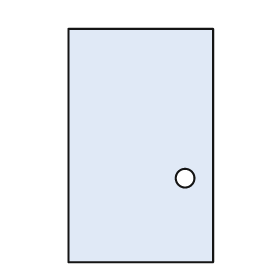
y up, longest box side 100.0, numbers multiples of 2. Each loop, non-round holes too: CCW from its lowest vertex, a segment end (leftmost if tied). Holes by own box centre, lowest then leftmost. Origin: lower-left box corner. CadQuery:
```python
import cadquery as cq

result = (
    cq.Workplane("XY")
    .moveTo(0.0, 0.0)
    .lineTo(62.0, 0.0)
    .lineTo(62.0, 100.0)
    .lineTo(0.0, 100.0)
    .close()
    .moveTo(50.0, 36.0)
    .circle(4.0)
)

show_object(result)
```